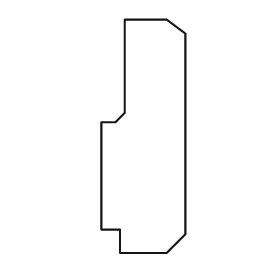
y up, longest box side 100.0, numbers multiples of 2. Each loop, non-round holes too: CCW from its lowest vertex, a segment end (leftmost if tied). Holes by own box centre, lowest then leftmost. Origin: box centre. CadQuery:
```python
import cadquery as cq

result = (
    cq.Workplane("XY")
    .moveTo(-10.0, -50.0)
    .lineTo(10.0, -50.0)
    .lineTo(18.0, -42.0)
    .lineTo(18.0, 44.0)
    .lineTo(10.0, 50.0)
    .lineTo(-8.0, 50.0)
    .lineTo(-8.0, 10.0)
    .lineTo(-12.0, 6.0)
    .lineTo(-18.0, 6.0)
    .lineTo(-18.0, -40.0)
    .lineTo(-10.0, -40.0)
    .close()
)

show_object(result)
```